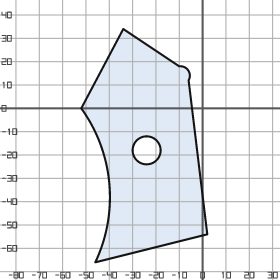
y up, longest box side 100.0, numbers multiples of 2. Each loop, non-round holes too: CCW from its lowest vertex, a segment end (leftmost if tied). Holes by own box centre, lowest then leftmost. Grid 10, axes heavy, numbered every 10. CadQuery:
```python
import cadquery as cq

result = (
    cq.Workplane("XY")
    .moveTo(-46.0, -66.0)
    .lineTo(2.0, -54.0)
    .lineTo(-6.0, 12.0)
    .threePointArc((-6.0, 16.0), (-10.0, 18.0))
    .lineTo(-34.0, 34.0)
    .lineTo(-52.0, 0.0)
    .threePointArc((-40.0, -32.0), (-46.0, -66.0))
    .close()
    .moveTo(-24.0, -18.0)
    .circle(6.0)
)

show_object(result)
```